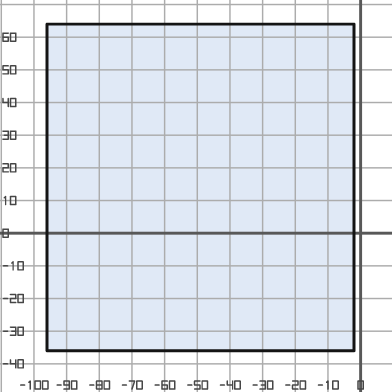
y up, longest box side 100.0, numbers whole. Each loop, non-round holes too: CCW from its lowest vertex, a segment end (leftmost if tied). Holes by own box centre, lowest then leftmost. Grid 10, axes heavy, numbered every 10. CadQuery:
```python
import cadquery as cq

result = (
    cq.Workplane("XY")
    .moveTo(-96.0, -36.0)
    .lineTo(-2.0, -36.0)
    .lineTo(-2.0, 64.0)
    .lineTo(-96.0, 64.0)
    .close()
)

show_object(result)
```